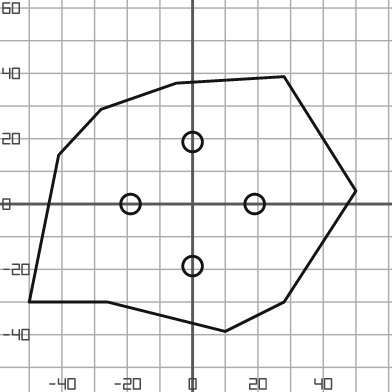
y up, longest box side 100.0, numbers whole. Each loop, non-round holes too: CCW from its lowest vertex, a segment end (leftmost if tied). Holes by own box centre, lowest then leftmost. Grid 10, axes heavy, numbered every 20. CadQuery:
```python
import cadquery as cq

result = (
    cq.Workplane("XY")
    .moveTo(10.0, -39.0)
    .lineTo(28.0, -30.0)
    .lineTo(50.0, 4.0)
    .lineTo(28.0, 39.0)
    .lineTo(-5.0, 37.0)
    .lineTo(-28.0, 29.0)
    .lineTo(-41.0, 15.0)
    .lineTo(-50.0, -30.0)
    .lineTo(-26.0, -30.0)
    .close()
    .moveTo(0.0, -19.0)
    .circle(3.0)
    .moveTo(-19.0, 0.0)
    .circle(3.0)
    .moveTo(19.0, 0.0)
    .circle(3.0)
    .moveTo(0.0, 19.0)
    .circle(3.0)
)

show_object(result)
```